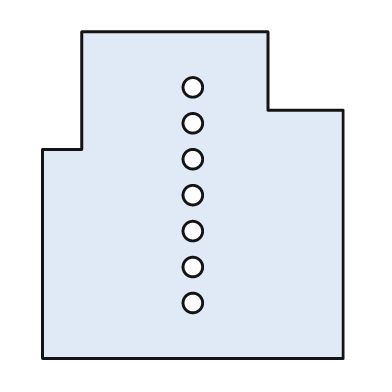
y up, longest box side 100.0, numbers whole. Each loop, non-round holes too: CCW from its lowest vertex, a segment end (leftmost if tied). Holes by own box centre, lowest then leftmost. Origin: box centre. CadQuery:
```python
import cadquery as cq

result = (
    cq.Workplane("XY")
    .moveTo(-46.0, -50.0)
    .lineTo(46.0, -50.0)
    .lineTo(46.0, 26.0)
    .lineTo(23.0, 26.0)
    .lineTo(23.0, 50.0)
    .lineTo(-34.0, 50.0)
    .lineTo(-34.0, 14.0)
    .lineTo(-46.0, 14.0)
    .close()
    .moveTo(0.0, -33.0)
    .circle(3.0)
    .moveTo(0.0, -22.0)
    .circle(3.0)
    .moveTo(0.0, -11.0)
    .circle(3.0)
    .moveTo(0.0, 0.0)
    .circle(3.0)
    .moveTo(0.0, 11.0)
    .circle(3.0)
    .moveTo(0.0, 22.0)
    .circle(3.0)
    .moveTo(0.0, 33.0)
    .circle(3.0)
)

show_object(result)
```